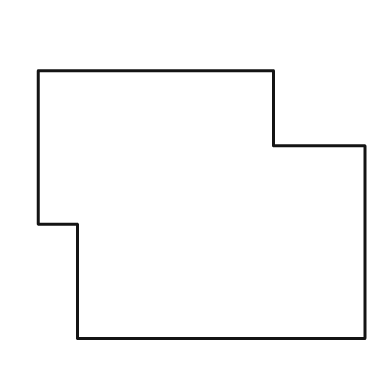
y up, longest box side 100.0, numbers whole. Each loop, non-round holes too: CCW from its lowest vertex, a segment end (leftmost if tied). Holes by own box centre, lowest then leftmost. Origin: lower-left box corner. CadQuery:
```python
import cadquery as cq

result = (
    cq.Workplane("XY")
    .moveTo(12.0, 0.0)
    .lineTo(100.0, 0.0)
    .lineTo(100.0, 59.0)
    .lineTo(72.0, 59.0)
    .lineTo(72.0, 82.0)
    .lineTo(0.0, 82.0)
    .lineTo(0.0, 35.0)
    .lineTo(12.0, 35.0)
    .close()
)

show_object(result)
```